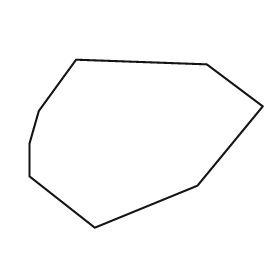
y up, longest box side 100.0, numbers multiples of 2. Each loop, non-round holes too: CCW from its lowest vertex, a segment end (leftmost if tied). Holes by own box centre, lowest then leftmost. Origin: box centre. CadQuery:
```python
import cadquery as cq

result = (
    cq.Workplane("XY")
    .moveTo(-22.0, -36.0)
    .lineTo(22.0, -18.0)
    .lineTo(50.0, 16.0)
    .lineTo(26.0, 34.0)
    .lineTo(-30.0, 36.0)
    .lineTo(-46.0, 14.0)
    .lineTo(-50.0, 0.0)
    .lineTo(-50.0, -14.0)
    .close()
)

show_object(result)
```